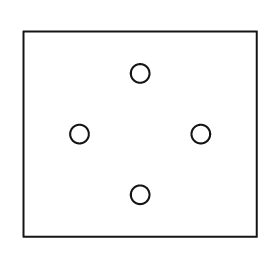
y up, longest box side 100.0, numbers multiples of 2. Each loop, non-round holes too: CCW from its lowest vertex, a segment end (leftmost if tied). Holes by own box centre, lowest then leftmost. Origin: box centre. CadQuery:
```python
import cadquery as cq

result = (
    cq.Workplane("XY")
    .moveTo(-50.0, -44.0)
    .lineTo(50.0, -44.0)
    .lineTo(50.0, 44.0)
    .lineTo(-50.0, 44.0)
    .close()
    .moveTo(0.0, -26.0)
    .circle(4.0)
    .moveTo(-26.0, 0.0)
    .circle(4.0)
    .moveTo(26.0, 0.0)
    .circle(4.0)
    .moveTo(0.0, 26.0)
    .circle(4.0)
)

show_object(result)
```